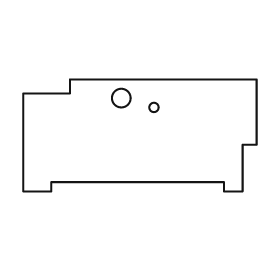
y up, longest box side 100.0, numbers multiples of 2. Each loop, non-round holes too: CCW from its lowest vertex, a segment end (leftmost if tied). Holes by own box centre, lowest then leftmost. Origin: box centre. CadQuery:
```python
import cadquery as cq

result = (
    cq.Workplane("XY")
    .moveTo(-50.0, -24.0)
    .lineTo(-38.0, -24.0)
    .lineTo(-38.0, -20.0)
    .lineTo(36.0, -20.0)
    .lineTo(36.0, -24.0)
    .lineTo(44.0, -24.0)
    .lineTo(44.0, -4.0)
    .lineTo(50.0, -4.0)
    .lineTo(50.0, 24.0)
    .lineTo(-30.0, 24.0)
    .lineTo(-30.0, 18.0)
    .lineTo(-50.0, 18.0)
    .close()
    .moveTo(6.0, 12.0)
    .circle(2.0)
    .moveTo(-8.0, 16.0)
    .circle(4.0)
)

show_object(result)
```